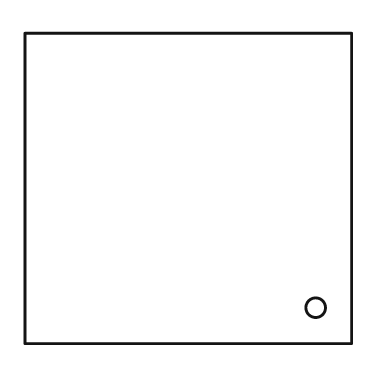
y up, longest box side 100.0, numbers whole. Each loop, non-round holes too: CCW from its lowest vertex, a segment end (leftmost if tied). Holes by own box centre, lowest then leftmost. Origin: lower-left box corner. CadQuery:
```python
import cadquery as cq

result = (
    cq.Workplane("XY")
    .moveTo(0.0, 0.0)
    .lineTo(100.0, 0.0)
    .lineTo(100.0, 95.0)
    .lineTo(0.0, 95.0)
    .close()
    .moveTo(89.0, 11.0)
    .circle(3.0)
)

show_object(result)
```